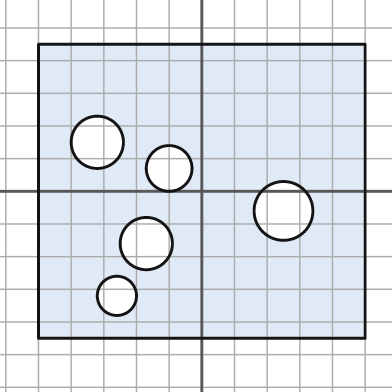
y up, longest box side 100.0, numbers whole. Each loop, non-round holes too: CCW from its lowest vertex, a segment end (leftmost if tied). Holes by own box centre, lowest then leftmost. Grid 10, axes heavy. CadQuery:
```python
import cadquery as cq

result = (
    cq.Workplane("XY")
    .moveTo(-50.0, -45.0)
    .lineTo(50.0, -45.0)
    .lineTo(50.0, 45.0)
    .lineTo(-50.0, 45.0)
    .close()
    .moveTo(-26.0, -32.0)
    .circle(6.0)
    .moveTo(-17.0, -16.0)
    .circle(8.0)
    .moveTo(25.0, -6.0)
    .circle(9.0)
    .moveTo(-10.0, 7.0)
    .circle(7.0)
    .moveTo(-32.0, 15.0)
    .circle(8.0)
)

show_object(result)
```